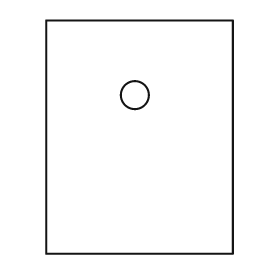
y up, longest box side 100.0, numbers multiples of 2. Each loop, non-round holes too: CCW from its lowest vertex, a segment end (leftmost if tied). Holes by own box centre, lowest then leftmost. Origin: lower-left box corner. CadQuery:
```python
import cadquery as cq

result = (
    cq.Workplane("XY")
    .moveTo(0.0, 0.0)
    .lineTo(80.0, 0.0)
    .lineTo(80.0, 100.0)
    .lineTo(0.0, 100.0)
    .close()
    .moveTo(38.0, 68.0)
    .circle(6.0)
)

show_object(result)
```